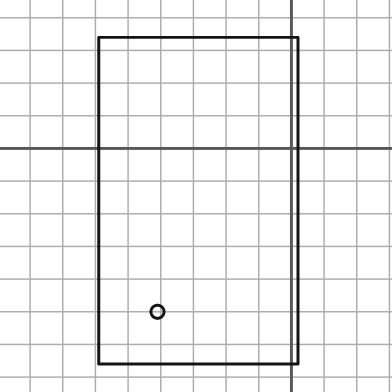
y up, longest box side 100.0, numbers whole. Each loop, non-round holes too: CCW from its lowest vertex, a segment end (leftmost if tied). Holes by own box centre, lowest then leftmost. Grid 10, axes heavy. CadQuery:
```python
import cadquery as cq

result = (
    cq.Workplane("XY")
    .moveTo(-59.0, -66.0)
    .lineTo(2.0, -66.0)
    .lineTo(2.0, 34.0)
    .lineTo(-59.0, 34.0)
    .close()
    .moveTo(-41.0, -50.0)
    .circle(2.0)
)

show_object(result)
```